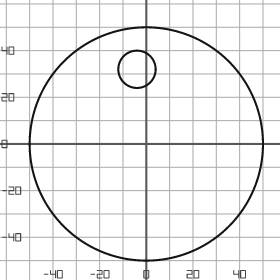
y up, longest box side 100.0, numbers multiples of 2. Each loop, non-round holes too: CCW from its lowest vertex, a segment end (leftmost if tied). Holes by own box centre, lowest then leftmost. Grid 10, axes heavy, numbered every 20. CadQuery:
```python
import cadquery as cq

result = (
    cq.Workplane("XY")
    .moveTo(0.0, 0.0)
    .circle(50.0)
    .moveTo(-4.0, 32.0)
    .circle(8.0)
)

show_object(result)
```